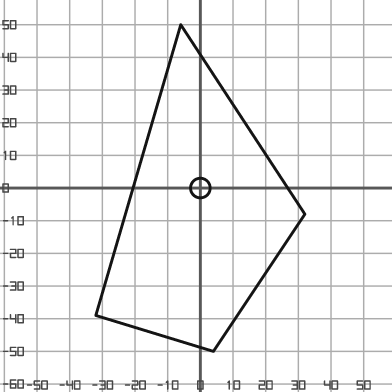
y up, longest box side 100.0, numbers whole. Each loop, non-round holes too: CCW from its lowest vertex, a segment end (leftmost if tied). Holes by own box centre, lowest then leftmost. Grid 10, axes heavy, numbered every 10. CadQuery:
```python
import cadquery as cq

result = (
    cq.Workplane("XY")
    .moveTo(4.0, -50.0)
    .lineTo(32.0, -8.0)
    .lineTo(-6.0, 50.0)
    .lineTo(-32.0, -39.0)
    .close()
    .moveTo(0.0, 0.0)
    .circle(3.0)
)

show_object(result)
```